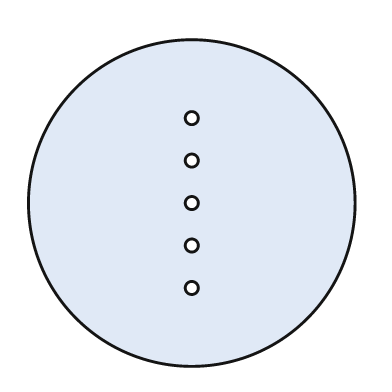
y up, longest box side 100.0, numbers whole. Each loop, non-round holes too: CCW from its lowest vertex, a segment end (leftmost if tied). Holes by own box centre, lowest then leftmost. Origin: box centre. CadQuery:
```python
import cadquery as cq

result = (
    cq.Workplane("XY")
    .moveTo(0.0, 0.0)
    .circle(50.0)
    .moveTo(0.0, -26.0)
    .circle(2.0)
    .moveTo(0.0, -13.0)
    .circle(2.0)
    .moveTo(0.0, 0.0)
    .circle(2.0)
    .moveTo(0.0, 13.0)
    .circle(2.0)
    .moveTo(0.0, 26.0)
    .circle(2.0)
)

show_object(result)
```